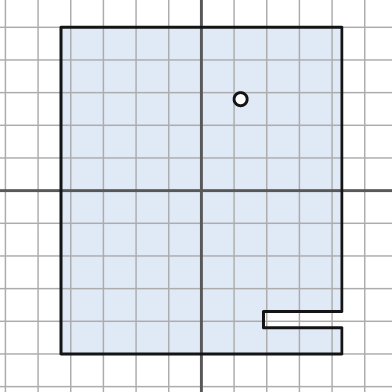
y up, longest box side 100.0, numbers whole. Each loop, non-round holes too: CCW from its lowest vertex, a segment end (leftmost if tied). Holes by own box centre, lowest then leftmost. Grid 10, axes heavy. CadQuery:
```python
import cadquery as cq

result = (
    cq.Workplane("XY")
    .moveTo(-43.0, -50.0)
    .lineTo(43.0, -50.0)
    .lineTo(43.0, -42.0)
    .lineTo(19.0, -42.0)
    .lineTo(19.0, -37.0)
    .lineTo(43.0, -37.0)
    .lineTo(43.0, 50.0)
    .lineTo(-43.0, 50.0)
    .close()
    .moveTo(12.0, 28.0)
    .circle(2.0)
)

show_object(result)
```